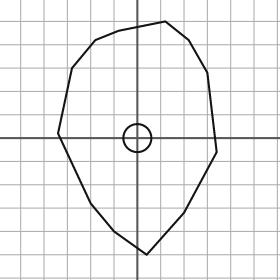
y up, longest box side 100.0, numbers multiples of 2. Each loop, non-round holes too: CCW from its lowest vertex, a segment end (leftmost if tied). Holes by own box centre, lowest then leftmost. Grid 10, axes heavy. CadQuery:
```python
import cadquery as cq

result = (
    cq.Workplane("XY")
    .moveTo(4.0, -50.0)
    .lineTo(20.0, -32.0)
    .lineTo(34.0, -6.0)
    .lineTo(30.0, 28.0)
    .lineTo(22.0, 42.0)
    .lineTo(12.0, 50.0)
    .lineTo(-8.0, 46.0)
    .lineTo(-18.0, 42.0)
    .lineTo(-28.0, 30.0)
    .lineTo(-34.0, 2.0)
    .lineTo(-20.0, -28.0)
    .lineTo(-10.0, -40.0)
    .close()
    .moveTo(0.0, 0.0)
    .circle(6.0)
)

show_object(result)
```